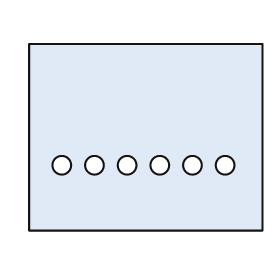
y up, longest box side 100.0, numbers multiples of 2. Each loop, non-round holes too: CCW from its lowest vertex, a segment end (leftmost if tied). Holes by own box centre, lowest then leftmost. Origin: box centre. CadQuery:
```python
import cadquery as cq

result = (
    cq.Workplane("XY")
    .moveTo(-50.0, -40.0)
    .lineTo(50.0, -40.0)
    .lineTo(50.0, 40.0)
    .lineTo(-50.0, 40.0)
    .close()
    .moveTo(-36.0, -12.0)
    .circle(4.0)
    .moveTo(-22.0, -12.0)
    .circle(4.0)
    .moveTo(-8.0, -12.0)
    .circle(4.0)
    .moveTo(6.0, -12.0)
    .circle(4.0)
    .moveTo(20.0, -12.0)
    .circle(4.0)
    .moveTo(34.0, -12.0)
    .circle(4.0)
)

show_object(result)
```